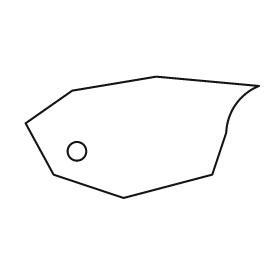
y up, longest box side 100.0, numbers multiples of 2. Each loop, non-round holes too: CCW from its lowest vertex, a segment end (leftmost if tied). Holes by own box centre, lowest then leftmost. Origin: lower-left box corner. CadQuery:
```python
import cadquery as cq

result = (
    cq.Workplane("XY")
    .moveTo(42.0, 0.0)
    .lineTo(80.0, 10.0)
    .lineTo(86.0, 28.0)
    .threePointArc((90.0, 40.0), (100.0, 48.0))
    .lineTo(56.0, 52.0)
    .lineTo(20.0, 46.0)
    .lineTo(0.0, 32.0)
    .lineTo(12.0, 10.0)
    .close()
    .moveTo(22.0, 20.0)
    .circle(4.0)
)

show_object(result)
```